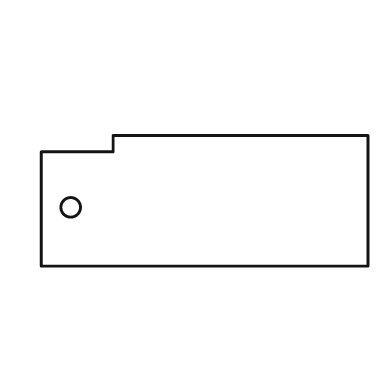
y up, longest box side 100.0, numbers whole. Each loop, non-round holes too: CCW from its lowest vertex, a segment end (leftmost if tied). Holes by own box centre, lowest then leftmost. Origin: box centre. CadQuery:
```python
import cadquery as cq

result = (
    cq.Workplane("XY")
    .moveTo(-50.0, -20.0)
    .lineTo(50.0, -20.0)
    .lineTo(50.0, 20.0)
    .lineTo(-28.0, 20.0)
    .lineTo(-28.0, 15.0)
    .lineTo(-50.0, 15.0)
    .close()
    .moveTo(-41.0, -2.0)
    .circle(3.0)
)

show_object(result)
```